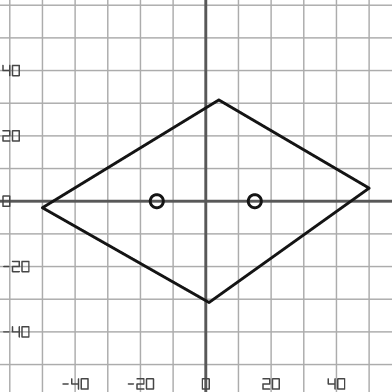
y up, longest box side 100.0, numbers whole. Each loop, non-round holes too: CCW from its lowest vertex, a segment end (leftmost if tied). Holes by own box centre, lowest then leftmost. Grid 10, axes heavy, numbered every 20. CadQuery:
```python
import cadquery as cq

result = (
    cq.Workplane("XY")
    .moveTo(1.0, -31.0)
    .lineTo(50.0, 4.0)
    .lineTo(4.0, 31.0)
    .lineTo(-50.0, -2.0)
    .close()
    .moveTo(-15.0, 0.0)
    .circle(2.0)
    .moveTo(15.0, 0.0)
    .circle(2.0)
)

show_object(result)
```